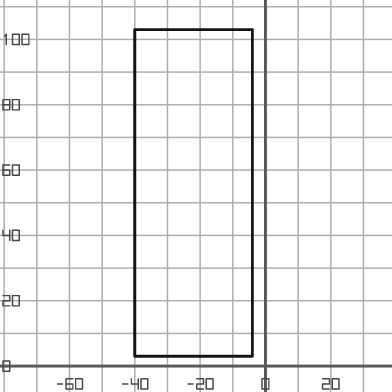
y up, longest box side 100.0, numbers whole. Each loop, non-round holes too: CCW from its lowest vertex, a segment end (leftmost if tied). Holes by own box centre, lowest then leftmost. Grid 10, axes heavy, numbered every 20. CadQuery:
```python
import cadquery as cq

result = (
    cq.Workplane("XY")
    .moveTo(-40.0, 3.0)
    .lineTo(-4.0, 3.0)
    .lineTo(-4.0, 103.0)
    .lineTo(-40.0, 103.0)
    .close()
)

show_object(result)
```